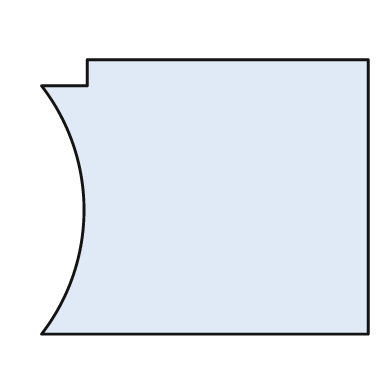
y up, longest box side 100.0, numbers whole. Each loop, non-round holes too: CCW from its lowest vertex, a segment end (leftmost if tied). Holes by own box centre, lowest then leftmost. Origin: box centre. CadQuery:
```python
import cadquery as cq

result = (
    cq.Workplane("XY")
    .moveTo(-50.0, -42.0)
    .lineTo(50.0, -42.0)
    .lineTo(50.0, 42.0)
    .lineTo(-36.0, 42.0)
    .lineTo(-36.0, 34.0)
    .lineTo(-50.0, 34.0)
    .threePointArc((-37.0, -4.0), (-50.0, -42.0))
    .close()
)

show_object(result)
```